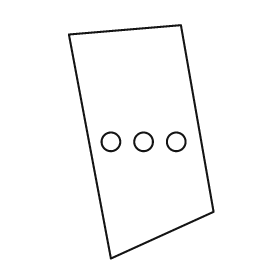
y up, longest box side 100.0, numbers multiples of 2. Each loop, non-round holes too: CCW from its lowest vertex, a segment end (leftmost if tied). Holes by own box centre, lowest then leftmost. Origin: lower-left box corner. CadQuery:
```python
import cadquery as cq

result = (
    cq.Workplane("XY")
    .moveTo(18.0, 0.0)
    .lineTo(62.0, 20.0)
    .lineTo(48.0, 100.0)
    .lineTo(0.0, 96.0)
    .close()
    .moveTo(18.0, 50.0)
    .circle(4.0)
    .moveTo(32.0, 50.0)
    .circle(4.0)
    .moveTo(46.0, 50.0)
    .circle(4.0)
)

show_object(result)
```